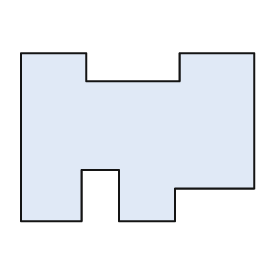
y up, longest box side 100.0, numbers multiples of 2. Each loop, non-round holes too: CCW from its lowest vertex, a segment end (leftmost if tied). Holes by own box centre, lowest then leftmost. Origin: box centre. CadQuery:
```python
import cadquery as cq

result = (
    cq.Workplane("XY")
    .moveTo(-50.0, -36.0)
    .lineTo(-24.0, -36.0)
    .lineTo(-24.0, -14.0)
    .lineTo(-8.0, -14.0)
    .lineTo(-8.0, -36.0)
    .lineTo(16.0, -36.0)
    .lineTo(16.0, -22.0)
    .lineTo(50.0, -22.0)
    .lineTo(50.0, 36.0)
    .lineTo(18.0, 36.0)
    .lineTo(18.0, 24.0)
    .lineTo(-22.0, 24.0)
    .lineTo(-22.0, 36.0)
    .lineTo(-50.0, 36.0)
    .close()
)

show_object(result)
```